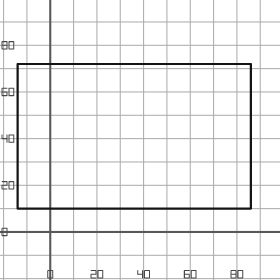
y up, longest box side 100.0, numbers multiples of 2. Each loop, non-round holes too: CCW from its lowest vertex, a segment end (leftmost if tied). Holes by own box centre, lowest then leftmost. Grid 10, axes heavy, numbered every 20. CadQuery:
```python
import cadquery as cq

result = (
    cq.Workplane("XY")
    .moveTo(-14.0, 10.0)
    .lineTo(86.0, 10.0)
    .lineTo(86.0, 72.0)
    .lineTo(-14.0, 72.0)
    .close()
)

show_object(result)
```